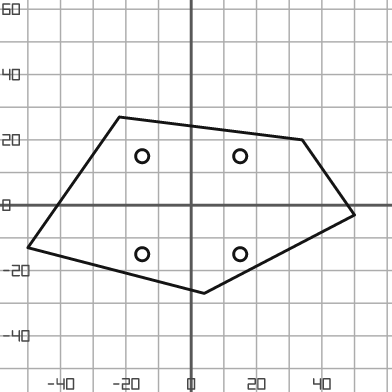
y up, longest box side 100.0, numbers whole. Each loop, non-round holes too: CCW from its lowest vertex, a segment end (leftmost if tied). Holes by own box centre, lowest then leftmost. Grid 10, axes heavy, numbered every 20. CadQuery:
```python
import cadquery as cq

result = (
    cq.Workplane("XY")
    .moveTo(4.0, -27.0)
    .lineTo(50.0, -3.0)
    .lineTo(34.0, 20.0)
    .lineTo(-22.0, 27.0)
    .lineTo(-50.0, -13.0)
    .close()
    .moveTo(-15.0, -15.0)
    .circle(2.0)
    .moveTo(15.0, -15.0)
    .circle(2.0)
    .moveTo(-15.0, 15.0)
    .circle(2.0)
    .moveTo(15.0, 15.0)
    .circle(2.0)
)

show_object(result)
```